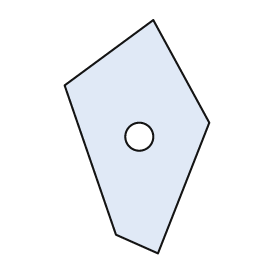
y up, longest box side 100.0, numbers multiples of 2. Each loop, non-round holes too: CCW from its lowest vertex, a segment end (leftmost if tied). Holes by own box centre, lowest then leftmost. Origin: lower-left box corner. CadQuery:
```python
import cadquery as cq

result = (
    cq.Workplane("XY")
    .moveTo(40.0, 0.0)
    .lineTo(62.0, 56.0)
    .lineTo(38.0, 100.0)
    .lineTo(0.0, 72.0)
    .lineTo(22.0, 8.0)
    .close()
    .moveTo(32.0, 50.0)
    .circle(6.0)
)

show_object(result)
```